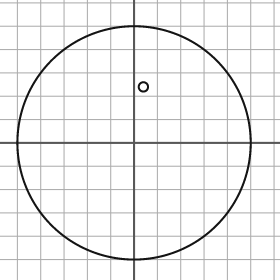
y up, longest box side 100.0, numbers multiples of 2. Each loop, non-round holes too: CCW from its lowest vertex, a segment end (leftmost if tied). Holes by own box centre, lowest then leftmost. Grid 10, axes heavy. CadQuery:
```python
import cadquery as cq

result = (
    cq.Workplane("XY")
    .moveTo(0.0, 0.0)
    .circle(50.0)
    .moveTo(4.0, 24.0)
    .circle(2.0)
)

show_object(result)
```